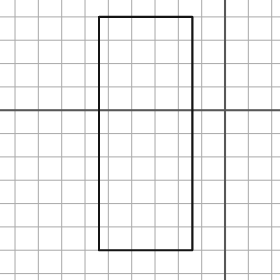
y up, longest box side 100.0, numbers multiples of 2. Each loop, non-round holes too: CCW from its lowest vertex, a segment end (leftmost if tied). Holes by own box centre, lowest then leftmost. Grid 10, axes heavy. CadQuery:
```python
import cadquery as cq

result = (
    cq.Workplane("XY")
    .moveTo(-54.0, -60.0)
    .lineTo(-14.0, -60.0)
    .lineTo(-14.0, 40.0)
    .lineTo(-54.0, 40.0)
    .close()
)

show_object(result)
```